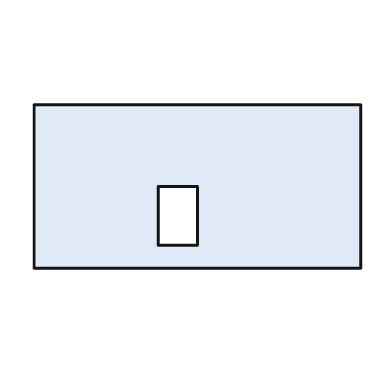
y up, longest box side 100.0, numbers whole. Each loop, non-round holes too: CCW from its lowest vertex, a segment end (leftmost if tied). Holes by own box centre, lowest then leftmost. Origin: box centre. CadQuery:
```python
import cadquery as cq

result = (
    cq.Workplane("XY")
    .moveTo(-50.0, -25.0)
    .lineTo(50.0, -25.0)
    .lineTo(50.0, 25.0)
    .lineTo(-50.0, 25.0)
    .close()
    .moveTo(-12.0, -18.0)
    .lineTo(0.0, -18.0)
    .lineTo(0.0, 0.0)
    .lineTo(-12.0, 0.0)
    .close()
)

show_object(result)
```